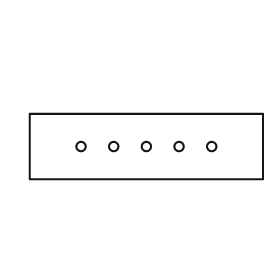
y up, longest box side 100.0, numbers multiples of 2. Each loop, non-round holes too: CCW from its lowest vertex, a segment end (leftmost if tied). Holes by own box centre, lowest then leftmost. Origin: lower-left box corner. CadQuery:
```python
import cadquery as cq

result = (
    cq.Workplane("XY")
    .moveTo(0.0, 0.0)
    .lineTo(100.0, 0.0)
    .lineTo(100.0, 28.0)
    .lineTo(0.0, 28.0)
    .close()
    .moveTo(22.0, 14.0)
    .circle(2.0)
    .moveTo(36.0, 14.0)
    .circle(2.0)
    .moveTo(50.0, 14.0)
    .circle(2.0)
    .moveTo(64.0, 14.0)
    .circle(2.0)
    .moveTo(78.0, 14.0)
    .circle(2.0)
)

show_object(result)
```